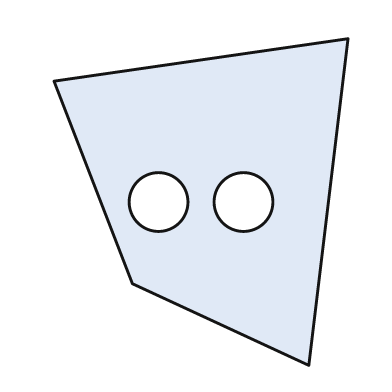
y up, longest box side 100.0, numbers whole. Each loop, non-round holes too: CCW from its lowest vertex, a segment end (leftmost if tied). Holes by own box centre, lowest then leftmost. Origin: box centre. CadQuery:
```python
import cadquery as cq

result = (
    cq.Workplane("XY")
    .moveTo(33.0, -50.0)
    .lineTo(45.0, 50.0)
    .lineTo(-45.0, 37.0)
    .lineTo(-21.0, -25.0)
    .close()
    .moveTo(-13.0, 0.0)
    .circle(9.0)
    .moveTo(13.0, 0.0)
    .circle(9.0)
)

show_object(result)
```